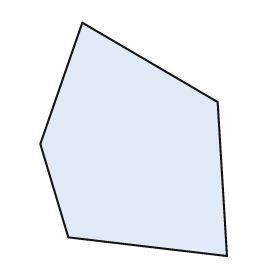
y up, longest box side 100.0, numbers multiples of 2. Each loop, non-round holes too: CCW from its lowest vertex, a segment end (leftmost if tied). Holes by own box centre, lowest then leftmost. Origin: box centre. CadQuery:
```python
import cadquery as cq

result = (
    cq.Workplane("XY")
    .moveTo(40.0, -50.0)
    .lineTo(36.0, 16.0)
    .lineTo(-22.0, 50.0)
    .lineTo(-40.0, -2.0)
    .lineTo(-28.0, -42.0)
    .close()
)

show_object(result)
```